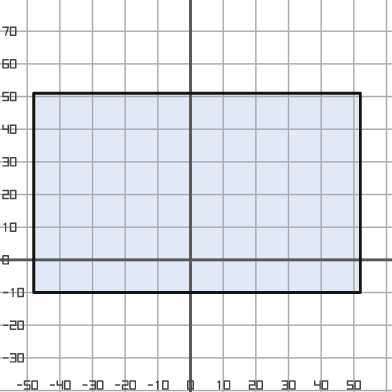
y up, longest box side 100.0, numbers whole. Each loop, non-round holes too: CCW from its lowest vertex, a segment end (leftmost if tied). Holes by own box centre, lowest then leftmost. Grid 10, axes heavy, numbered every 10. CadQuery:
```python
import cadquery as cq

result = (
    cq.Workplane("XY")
    .moveTo(-48.0, -10.0)
    .lineTo(52.0, -10.0)
    .lineTo(52.0, 51.0)
    .lineTo(-48.0, 51.0)
    .close()
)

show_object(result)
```